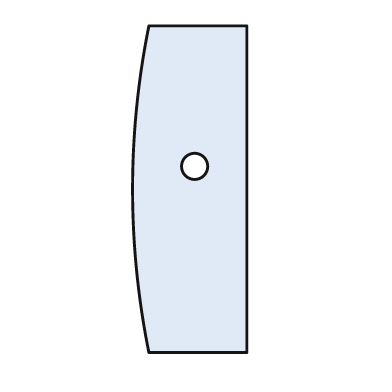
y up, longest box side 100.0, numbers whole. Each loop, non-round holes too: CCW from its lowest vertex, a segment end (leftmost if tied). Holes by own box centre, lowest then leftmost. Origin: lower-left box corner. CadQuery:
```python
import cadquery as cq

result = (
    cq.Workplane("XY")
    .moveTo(5.0, 0.0)
    .lineTo(35.0, 0.0)
    .lineTo(35.0, 100.0)
    .lineTo(5.0, 100.0)
    .threePointArc((0.0, 50.0), (5.0, 0.0))
    .close()
    .moveTo(19.0, 57.0)
    .circle(4.0)
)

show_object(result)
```